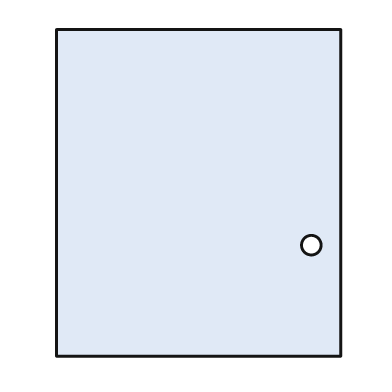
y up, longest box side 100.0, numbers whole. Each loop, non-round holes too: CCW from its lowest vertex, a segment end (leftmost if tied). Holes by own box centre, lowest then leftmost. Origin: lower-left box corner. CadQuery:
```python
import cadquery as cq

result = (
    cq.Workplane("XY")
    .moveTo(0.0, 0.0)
    .lineTo(87.0, 0.0)
    .lineTo(87.0, 100.0)
    .lineTo(0.0, 100.0)
    .close()
    .moveTo(78.0, 34.0)
    .circle(3.0)
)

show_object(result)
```